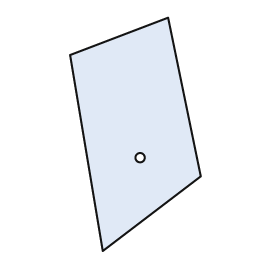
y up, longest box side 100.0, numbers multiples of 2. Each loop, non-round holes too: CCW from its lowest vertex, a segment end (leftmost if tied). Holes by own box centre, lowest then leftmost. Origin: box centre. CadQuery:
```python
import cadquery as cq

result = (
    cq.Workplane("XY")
    .moveTo(-14.0, -50.0)
    .lineTo(28.0, -18.0)
    .lineTo(14.0, 50.0)
    .lineTo(-28.0, 34.0)
    .close()
    .moveTo(2.0, -10.0)
    .circle(2.0)
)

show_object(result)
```